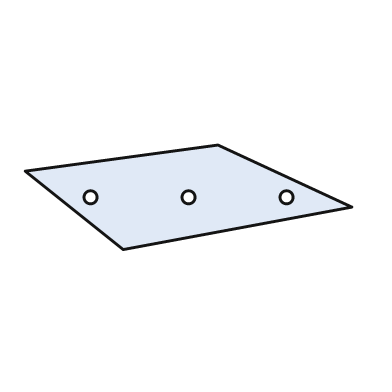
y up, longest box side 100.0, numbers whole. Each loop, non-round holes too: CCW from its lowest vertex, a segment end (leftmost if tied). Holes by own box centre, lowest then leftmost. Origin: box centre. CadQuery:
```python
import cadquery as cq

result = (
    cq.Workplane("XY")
    .moveTo(-20.0, -16.0)
    .lineTo(50.0, -3.0)
    .lineTo(9.0, 16.0)
    .lineTo(-50.0, 8.0)
    .close()
    .moveTo(-30.0, 0.0)
    .circle(2.0)
    .moveTo(0.0, 0.0)
    .circle(2.0)
    .moveTo(30.0, 0.0)
    .circle(2.0)
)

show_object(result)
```